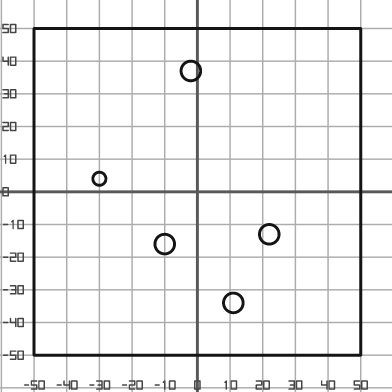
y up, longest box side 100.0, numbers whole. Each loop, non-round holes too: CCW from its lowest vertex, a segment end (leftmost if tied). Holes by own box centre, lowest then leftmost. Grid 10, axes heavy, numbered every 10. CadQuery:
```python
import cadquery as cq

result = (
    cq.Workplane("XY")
    .moveTo(-50.0, -50.0)
    .lineTo(50.0, -50.0)
    .lineTo(50.0, 50.0)
    .lineTo(-50.0, 50.0)
    .close()
    .moveTo(11.0, -34.0)
    .circle(3.0)
    .moveTo(-10.0, -16.0)
    .circle(3.0)
    .moveTo(22.0, -13.0)
    .circle(3.0)
    .moveTo(-30.0, 4.0)
    .circle(2.0)
    .moveTo(-2.0, 37.0)
    .circle(3.0)
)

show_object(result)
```